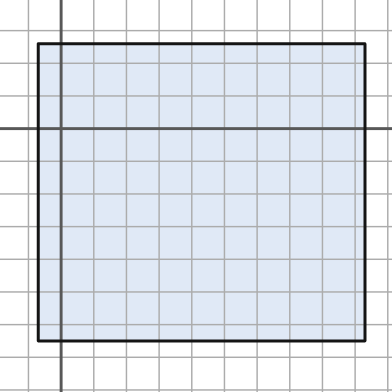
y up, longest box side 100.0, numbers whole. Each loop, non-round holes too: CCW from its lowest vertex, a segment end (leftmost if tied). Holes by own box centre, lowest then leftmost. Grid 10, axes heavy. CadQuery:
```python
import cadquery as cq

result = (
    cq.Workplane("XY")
    .moveTo(-7.0, -65.0)
    .lineTo(93.0, -65.0)
    .lineTo(93.0, 26.0)
    .lineTo(-7.0, 26.0)
    .close()
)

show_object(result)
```